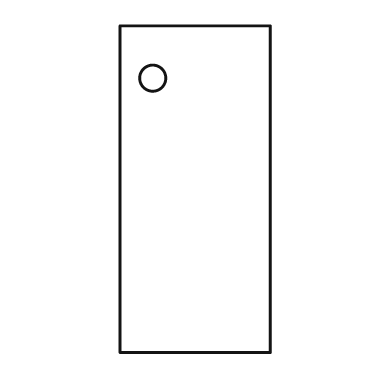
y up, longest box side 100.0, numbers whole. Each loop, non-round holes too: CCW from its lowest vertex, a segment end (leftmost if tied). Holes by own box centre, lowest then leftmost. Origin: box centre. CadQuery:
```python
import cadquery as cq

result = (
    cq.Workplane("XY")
    .moveTo(-23.0, -50.0)
    .lineTo(23.0, -50.0)
    .lineTo(23.0, 50.0)
    .lineTo(-23.0, 50.0)
    .close()
    .moveTo(-13.0, 34.0)
    .circle(4.0)
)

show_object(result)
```